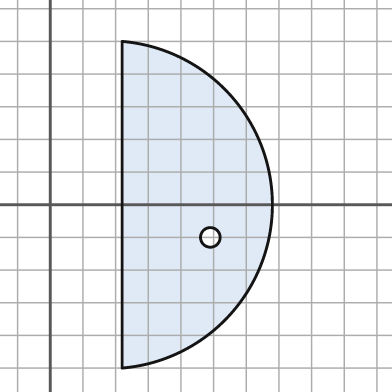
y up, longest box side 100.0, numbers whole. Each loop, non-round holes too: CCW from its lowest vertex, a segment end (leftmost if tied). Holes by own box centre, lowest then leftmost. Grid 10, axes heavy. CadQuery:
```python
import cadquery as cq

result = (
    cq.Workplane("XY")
    .moveTo(22.0, -50.0)
    .threePointArc((68.0, 0.0), (22.0, 50.0))
    .close()
    .moveTo(49.0, -10.0)
    .circle(3.0)
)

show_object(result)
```